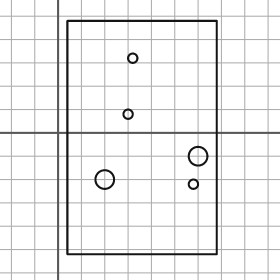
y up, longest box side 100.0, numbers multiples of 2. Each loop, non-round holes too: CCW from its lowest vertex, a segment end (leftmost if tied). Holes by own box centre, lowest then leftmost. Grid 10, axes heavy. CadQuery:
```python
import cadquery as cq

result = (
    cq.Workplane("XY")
    .moveTo(4.0, -52.0)
    .lineTo(68.0, -52.0)
    .lineTo(68.0, 48.0)
    .lineTo(4.0, 48.0)
    .close()
    .moveTo(58.0, -22.0)
    .circle(2.0)
    .moveTo(20.0, -20.0)
    .circle(4.0)
    .moveTo(60.0, -10.0)
    .circle(4.0)
    .moveTo(30.0, 8.0)
    .circle(2.0)
    .moveTo(32.0, 32.0)
    .circle(2.0)
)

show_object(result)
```